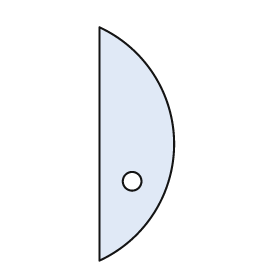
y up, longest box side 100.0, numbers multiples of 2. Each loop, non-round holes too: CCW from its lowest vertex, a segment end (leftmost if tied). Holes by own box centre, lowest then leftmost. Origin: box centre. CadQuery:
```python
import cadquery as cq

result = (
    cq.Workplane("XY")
    .moveTo(-16.0, -50.0)
    .threePointArc((16.0, 0.0), (-16.0, 50.0))
    .close()
    .moveTo(-2.0, -16.0)
    .circle(4.0)
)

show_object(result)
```